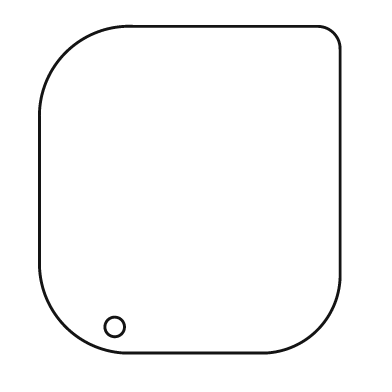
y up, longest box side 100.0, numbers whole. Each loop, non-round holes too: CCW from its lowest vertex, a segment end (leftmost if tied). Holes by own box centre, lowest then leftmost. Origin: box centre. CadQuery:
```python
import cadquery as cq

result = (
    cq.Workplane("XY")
    .moveTo(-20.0, -50.0)
    .lineTo(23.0, -50.0)
    .threePointArc((39.0, -43.0), (46.0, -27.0))
    .lineTo(46.0, 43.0)
    .threePointArc((44.0, 48.0), (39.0, 50.0))
    .lineTo(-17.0, 50.0)
    .threePointArc((-38.0, 42.0), (-46.0, 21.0))
    .lineTo(-46.0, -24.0)
    .threePointArc((-38.0, -42.0), (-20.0, -50.0))
    .close()
    .moveTo(-23.0, -42.0)
    .circle(3.0)
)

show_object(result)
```